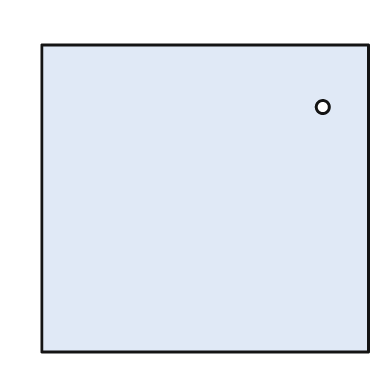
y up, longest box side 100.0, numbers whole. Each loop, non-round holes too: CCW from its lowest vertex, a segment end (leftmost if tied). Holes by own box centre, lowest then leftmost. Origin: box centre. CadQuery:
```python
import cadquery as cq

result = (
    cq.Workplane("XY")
    .moveTo(-50.0, -47.0)
    .lineTo(50.0, -47.0)
    .lineTo(50.0, 47.0)
    .lineTo(-50.0, 47.0)
    .close()
    .moveTo(36.0, 28.0)
    .circle(2.0)
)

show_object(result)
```